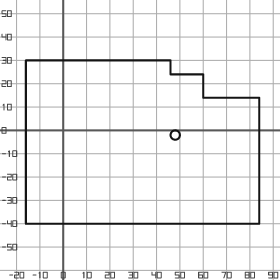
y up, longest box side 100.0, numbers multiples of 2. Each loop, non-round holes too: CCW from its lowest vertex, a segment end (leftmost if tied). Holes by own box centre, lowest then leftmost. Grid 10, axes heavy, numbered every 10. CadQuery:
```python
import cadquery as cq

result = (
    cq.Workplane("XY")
    .moveTo(-16.0, -40.0)
    .lineTo(84.0, -40.0)
    .lineTo(84.0, 14.0)
    .lineTo(60.0, 14.0)
    .lineTo(60.0, 24.0)
    .lineTo(46.0, 24.0)
    .lineTo(46.0, 30.0)
    .lineTo(-16.0, 30.0)
    .close()
    .moveTo(48.0, -2.0)
    .circle(2.0)
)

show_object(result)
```